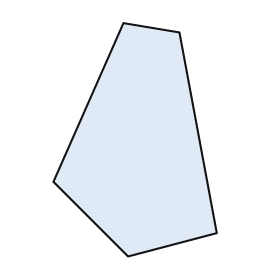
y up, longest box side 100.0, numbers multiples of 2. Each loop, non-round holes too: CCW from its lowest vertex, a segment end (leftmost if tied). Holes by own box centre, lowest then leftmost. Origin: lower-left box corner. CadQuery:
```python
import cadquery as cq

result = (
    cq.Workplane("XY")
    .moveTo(32.0, 0.0)
    .lineTo(70.0, 10.0)
    .lineTo(54.0, 96.0)
    .lineTo(30.0, 100.0)
    .lineTo(0.0, 32.0)
    .close()
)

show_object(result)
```